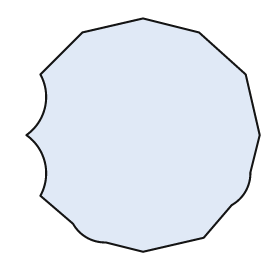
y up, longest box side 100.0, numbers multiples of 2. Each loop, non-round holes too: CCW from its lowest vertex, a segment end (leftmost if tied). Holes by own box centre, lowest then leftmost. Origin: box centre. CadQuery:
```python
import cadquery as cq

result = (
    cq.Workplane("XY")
    .moveTo(0.0, -50.0)
    .lineTo(26.0, -44.0)
    .lineTo(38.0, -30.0)
    .threePointArc((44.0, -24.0), (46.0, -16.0))
    .lineTo(50.0, 0.0)
    .lineTo(44.0, 26.0)
    .lineTo(24.0, 44.0)
    .lineTo(0.0, 50.0)
    .lineTo(-26.0, 44.0)
    .lineTo(-44.0, 26.0)
    .threePointArc((-42.0, 12.0), (-50.0, 0.0))
    .threePointArc((-42.0, -12.0), (-44.0, -26.0))
    .lineTo(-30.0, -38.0)
    .threePointArc((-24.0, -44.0), (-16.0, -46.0))
    .close()
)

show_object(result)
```